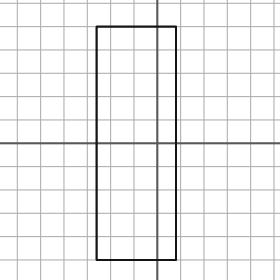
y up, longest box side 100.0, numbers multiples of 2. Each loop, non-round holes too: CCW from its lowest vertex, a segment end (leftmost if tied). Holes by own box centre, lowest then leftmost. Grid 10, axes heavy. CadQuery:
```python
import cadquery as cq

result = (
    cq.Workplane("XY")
    .moveTo(-26.0, -50.0)
    .lineTo(8.0, -50.0)
    .lineTo(8.0, 50.0)
    .lineTo(-26.0, 50.0)
    .close()
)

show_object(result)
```